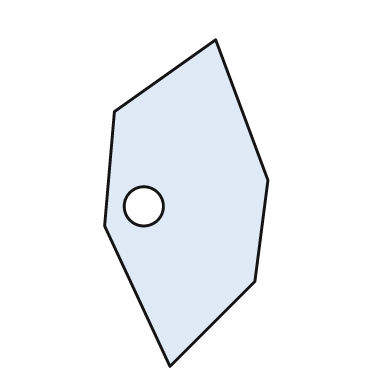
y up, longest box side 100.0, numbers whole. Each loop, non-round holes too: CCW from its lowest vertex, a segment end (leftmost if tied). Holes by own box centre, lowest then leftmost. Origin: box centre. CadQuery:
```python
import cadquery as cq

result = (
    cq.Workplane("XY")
    .moveTo(-5.0, -50.0)
    .lineTo(21.0, -24.0)
    .lineTo(25.0, 7.0)
    .lineTo(9.0, 50.0)
    .lineTo(-22.0, 28.0)
    .lineTo(-25.0, -7.0)
    .close()
    .moveTo(-13.0, -1.0)
    .circle(6.0)
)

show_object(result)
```